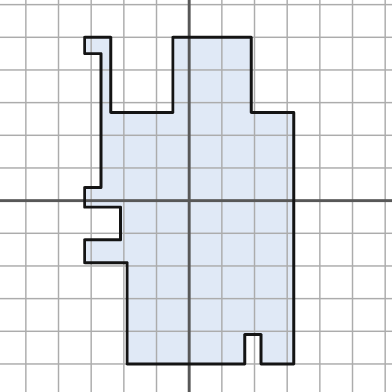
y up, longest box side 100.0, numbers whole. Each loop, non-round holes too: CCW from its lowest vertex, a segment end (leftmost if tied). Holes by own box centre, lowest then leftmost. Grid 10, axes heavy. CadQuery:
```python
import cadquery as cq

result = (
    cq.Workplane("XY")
    .moveTo(-19.0, -50.0)
    .lineTo(17.0, -50.0)
    .lineTo(17.0, -41.0)
    .lineTo(22.0, -41.0)
    .lineTo(22.0, -50.0)
    .lineTo(32.0, -50.0)
    .lineTo(32.0, 27.0)
    .lineTo(19.0, 27.0)
    .lineTo(19.0, 50.0)
    .lineTo(-5.0, 50.0)
    .lineTo(-5.0, 27.0)
    .lineTo(-24.0, 27.0)
    .lineTo(-24.0, 50.0)
    .lineTo(-32.0, 50.0)
    .lineTo(-32.0, 45.0)
    .lineTo(-27.0, 45.0)
    .lineTo(-27.0, 4.0)
    .lineTo(-32.0, 4.0)
    .lineTo(-32.0, -2.0)
    .lineTo(-21.0, -2.0)
    .lineTo(-21.0, -12.0)
    .lineTo(-32.0, -12.0)
    .lineTo(-32.0, -19.0)
    .lineTo(-19.0, -19.0)
    .close()
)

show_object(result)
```